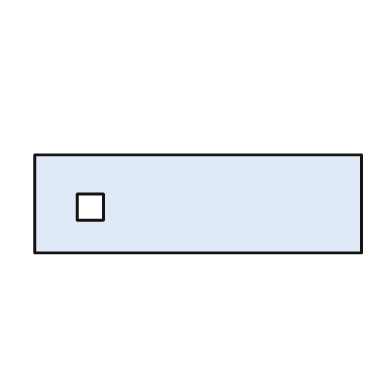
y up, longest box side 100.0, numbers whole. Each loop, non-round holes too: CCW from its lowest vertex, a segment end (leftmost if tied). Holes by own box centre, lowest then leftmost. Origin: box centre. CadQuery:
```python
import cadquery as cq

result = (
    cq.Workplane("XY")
    .moveTo(-50.0, -15.0)
    .lineTo(50.0, -15.0)
    .lineTo(50.0, 15.0)
    .lineTo(-50.0, 15.0)
    .close()
    .moveTo(-37.0, -5.0)
    .lineTo(-29.0, -5.0)
    .lineTo(-29.0, 3.0)
    .lineTo(-37.0, 3.0)
    .close()
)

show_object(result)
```